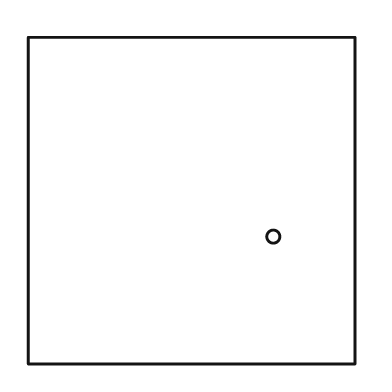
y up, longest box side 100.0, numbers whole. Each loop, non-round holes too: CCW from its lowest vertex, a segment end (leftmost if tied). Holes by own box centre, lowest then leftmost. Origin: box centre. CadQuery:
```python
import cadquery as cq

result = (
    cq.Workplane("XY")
    .moveTo(-50.0, -50.0)
    .lineTo(50.0, -50.0)
    .lineTo(50.0, 50.0)
    .lineTo(-50.0, 50.0)
    .close()
    .moveTo(25.0, -11.0)
    .circle(2.0)
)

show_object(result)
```